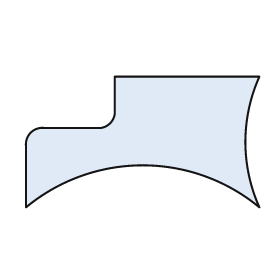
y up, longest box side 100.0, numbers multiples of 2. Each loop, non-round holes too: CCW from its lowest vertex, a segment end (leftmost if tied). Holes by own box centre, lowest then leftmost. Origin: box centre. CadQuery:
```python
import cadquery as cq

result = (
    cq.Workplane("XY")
    .moveTo(-50.0, -28.0)
    .threePointArc((0.0, -10.0), (50.0, -28.0))
    .threePointArc((44.0, 0.0), (50.0, 28.0))
    .lineTo(-12.0, 28.0)
    .lineTo(-12.0, 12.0)
    .threePointArc((-14.0, 8.0), (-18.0, 6.0))
    .lineTo(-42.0, 6.0)
    .threePointArc((-48.0, 4.0), (-50.0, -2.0))
    .close()
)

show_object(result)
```